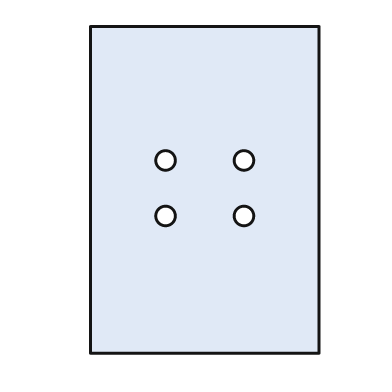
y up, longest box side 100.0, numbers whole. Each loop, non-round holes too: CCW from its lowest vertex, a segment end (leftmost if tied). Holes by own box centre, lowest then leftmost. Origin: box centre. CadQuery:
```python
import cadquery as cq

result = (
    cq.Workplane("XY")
    .moveTo(-35.0, -50.0)
    .lineTo(35.0, -50.0)
    .lineTo(35.0, 50.0)
    .lineTo(-35.0, 50.0)
    .close()
    .moveTo(-12.0, -8.0)
    .circle(3.0)
    .moveTo(12.0, -8.0)
    .circle(3.0)
    .moveTo(-12.0, 9.0)
    .circle(3.0)
    .moveTo(12.0, 9.0)
    .circle(3.0)
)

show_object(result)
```